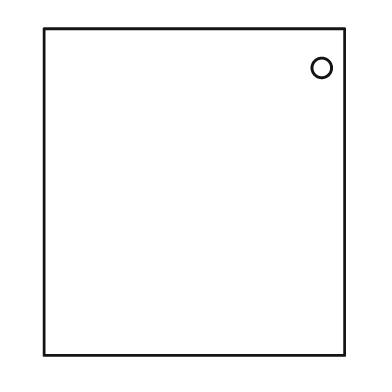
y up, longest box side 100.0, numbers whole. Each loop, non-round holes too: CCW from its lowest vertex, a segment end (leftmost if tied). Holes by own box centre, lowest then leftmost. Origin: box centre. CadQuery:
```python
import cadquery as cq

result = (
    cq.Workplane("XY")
    .moveTo(-46.0, -50.0)
    .lineTo(46.0, -50.0)
    .lineTo(46.0, 50.0)
    .lineTo(-46.0, 50.0)
    .close()
    .moveTo(39.0, 38.0)
    .circle(3.0)
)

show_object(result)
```